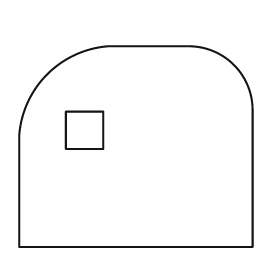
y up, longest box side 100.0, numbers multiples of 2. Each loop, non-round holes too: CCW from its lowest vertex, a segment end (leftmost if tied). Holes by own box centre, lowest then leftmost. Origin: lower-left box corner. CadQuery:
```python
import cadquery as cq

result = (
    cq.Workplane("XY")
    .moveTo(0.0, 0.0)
    .lineTo(100.0, 0.0)
    .lineTo(100.0, 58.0)
    .threePointArc((92.0, 78.0), (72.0, 86.0))
    .lineTo(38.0, 86.0)
    .threePointArc((12.0, 74.0), (0.0, 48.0))
    .close()
    .moveTo(20.0, 42.0)
    .lineTo(36.0, 42.0)
    .lineTo(36.0, 58.0)
    .lineTo(20.0, 58.0)
    .close()
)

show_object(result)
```